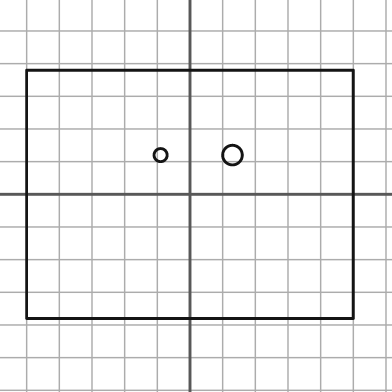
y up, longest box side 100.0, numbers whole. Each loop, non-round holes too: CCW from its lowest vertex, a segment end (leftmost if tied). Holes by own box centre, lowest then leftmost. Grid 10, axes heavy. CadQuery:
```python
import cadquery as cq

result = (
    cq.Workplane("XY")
    .moveTo(-50.0, -38.0)
    .lineTo(50.0, -38.0)
    .lineTo(50.0, 38.0)
    .lineTo(-50.0, 38.0)
    .close()
    .moveTo(-9.0, 12.0)
    .circle(2.0)
    .moveTo(13.0, 12.0)
    .circle(3.0)
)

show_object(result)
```